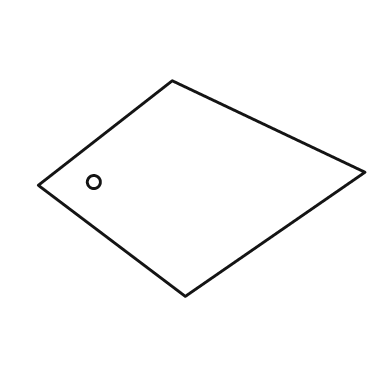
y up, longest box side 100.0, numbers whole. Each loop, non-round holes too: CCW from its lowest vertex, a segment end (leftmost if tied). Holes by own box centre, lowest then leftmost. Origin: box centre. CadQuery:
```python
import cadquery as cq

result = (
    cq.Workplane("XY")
    .moveTo(-5.0, -33.0)
    .lineTo(50.0, 5.0)
    .lineTo(-9.0, 33.0)
    .lineTo(-50.0, 1.0)
    .close()
    .moveTo(-33.0, 2.0)
    .circle(2.0)
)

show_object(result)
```